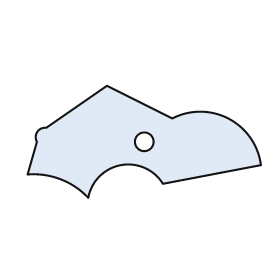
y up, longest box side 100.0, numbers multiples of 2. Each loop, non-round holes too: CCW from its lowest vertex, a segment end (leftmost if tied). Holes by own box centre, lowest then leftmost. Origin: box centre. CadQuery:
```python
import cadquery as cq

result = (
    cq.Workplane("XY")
    .moveTo(-24.0, -24.0)
    .threePointArc((-10.0, -10.0), (8.0, -18.0))
    .lineTo(50.0, -10.0)
    .threePointArc((36.0, 10.0), (12.0, 10.0))
    .lineTo(-16.0, 24.0)
    .lineTo(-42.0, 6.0)
    .threePointArc((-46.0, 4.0), (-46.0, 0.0))
    .lineTo(-50.0, -14.0)
    .threePointArc((-36.0, -16.0), (-24.0, -24.0))
    .close()
    .moveTo(0.0, 0.0)
    .circle(4.0)
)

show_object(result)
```